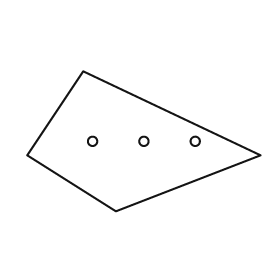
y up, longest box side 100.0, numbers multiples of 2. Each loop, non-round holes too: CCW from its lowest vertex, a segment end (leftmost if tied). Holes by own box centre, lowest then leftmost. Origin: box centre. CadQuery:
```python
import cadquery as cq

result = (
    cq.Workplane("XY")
    .moveTo(-12.0, -30.0)
    .lineTo(50.0, -6.0)
    .lineTo(-26.0, 30.0)
    .lineTo(-50.0, -6.0)
    .close()
    .moveTo(-22.0, 0.0)
    .circle(2.0)
    .moveTo(0.0, 0.0)
    .circle(2.0)
    .moveTo(22.0, 0.0)
    .circle(2.0)
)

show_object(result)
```